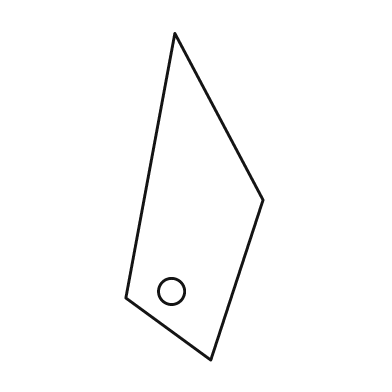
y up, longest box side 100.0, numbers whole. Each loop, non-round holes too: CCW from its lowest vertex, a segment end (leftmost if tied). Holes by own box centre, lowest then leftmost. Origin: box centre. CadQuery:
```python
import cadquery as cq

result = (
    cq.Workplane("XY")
    .moveTo(5.0, -50.0)
    .lineTo(21.0, -1.0)
    .lineTo(-6.0, 50.0)
    .lineTo(-21.0, -31.0)
    .close()
    .moveTo(-7.0, -29.0)
    .circle(4.0)
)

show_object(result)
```